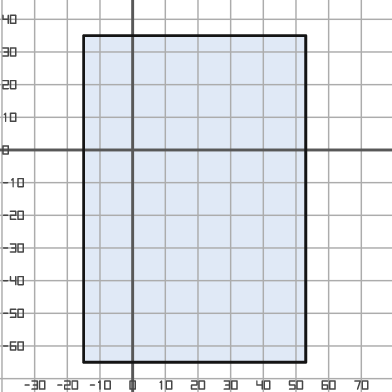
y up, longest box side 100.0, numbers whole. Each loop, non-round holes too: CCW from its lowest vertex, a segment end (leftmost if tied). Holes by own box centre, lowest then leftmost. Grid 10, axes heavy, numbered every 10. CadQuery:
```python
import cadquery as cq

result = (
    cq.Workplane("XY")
    .moveTo(-15.0, -65.0)
    .lineTo(53.0, -65.0)
    .lineTo(53.0, 35.0)
    .lineTo(-15.0, 35.0)
    .close()
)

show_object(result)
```